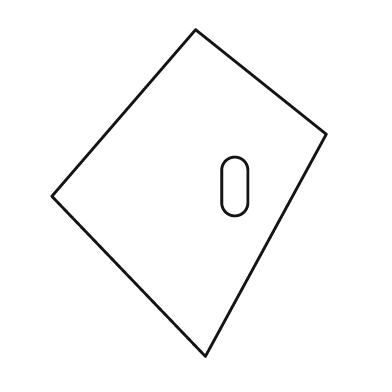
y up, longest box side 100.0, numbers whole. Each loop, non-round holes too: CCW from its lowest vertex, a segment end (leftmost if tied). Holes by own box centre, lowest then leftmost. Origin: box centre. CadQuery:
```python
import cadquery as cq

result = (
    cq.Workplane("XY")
    .moveTo(5.0, -50.0)
    .lineTo(42.0, 18.0)
    .lineTo(2.0, 50.0)
    .lineTo(-42.0, -1.0)
    .close()
    .moveTo(10.0, -3.0)
    .threePointArc((14.0, -7.0), (18.0, -3.0))
    .lineTo(18.0, 7.0)
    .threePointArc((14.0, 11.0), (10.0, 7.0))
    .close()
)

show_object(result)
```